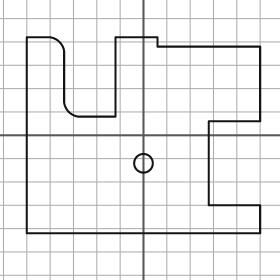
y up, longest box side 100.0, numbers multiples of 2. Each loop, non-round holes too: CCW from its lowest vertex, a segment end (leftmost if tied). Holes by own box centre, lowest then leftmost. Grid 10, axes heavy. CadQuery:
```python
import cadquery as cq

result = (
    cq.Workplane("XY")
    .moveTo(-50.0, -42.0)
    .lineTo(50.0, -42.0)
    .lineTo(50.0, -30.0)
    .lineTo(28.0, -30.0)
    .lineTo(28.0, 6.0)
    .lineTo(50.0, 6.0)
    .lineTo(50.0, 38.0)
    .lineTo(6.0, 38.0)
    .lineTo(6.0, 42.0)
    .lineTo(-12.0, 42.0)
    .lineTo(-12.0, 8.0)
    .lineTo(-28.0, 8.0)
    .threePointArc((-32.0, 10.0), (-34.0, 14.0))
    .lineTo(-34.0, 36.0)
    .threePointArc((-36.0, 40.0), (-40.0, 42.0))
    .lineTo(-50.0, 42.0)
    .close()
    .moveTo(0.0, -12.0)
    .circle(4.0)
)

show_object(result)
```